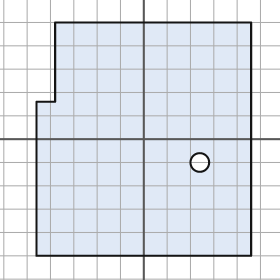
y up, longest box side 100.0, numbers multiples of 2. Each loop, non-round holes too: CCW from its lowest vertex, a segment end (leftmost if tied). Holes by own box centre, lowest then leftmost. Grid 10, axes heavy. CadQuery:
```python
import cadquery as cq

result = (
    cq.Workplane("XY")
    .moveTo(-46.0, -50.0)
    .lineTo(46.0, -50.0)
    .lineTo(46.0, 50.0)
    .lineTo(-38.0, 50.0)
    .lineTo(-38.0, 16.0)
    .lineTo(-46.0, 16.0)
    .close()
    .moveTo(24.0, -10.0)
    .circle(4.0)
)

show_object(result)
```